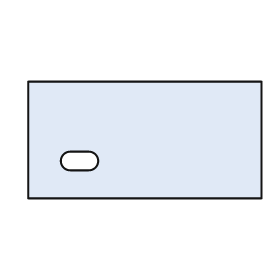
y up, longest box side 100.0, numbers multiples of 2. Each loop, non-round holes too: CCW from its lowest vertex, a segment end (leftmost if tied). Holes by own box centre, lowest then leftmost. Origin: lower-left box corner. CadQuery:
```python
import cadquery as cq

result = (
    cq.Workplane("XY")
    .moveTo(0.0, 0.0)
    .lineTo(100.0, 0.0)
    .lineTo(100.0, 50.0)
    .lineTo(0.0, 50.0)
    .close()
    .moveTo(18.0, 12.0)
    .lineTo(26.0, 12.0)
    .threePointArc((30.0, 16.0), (26.0, 20.0))
    .lineTo(18.0, 20.0)
    .threePointArc((14.0, 16.0), (18.0, 12.0))
    .close()
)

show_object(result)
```